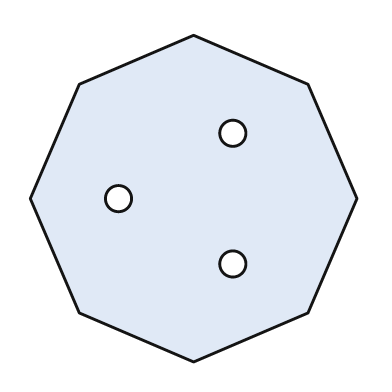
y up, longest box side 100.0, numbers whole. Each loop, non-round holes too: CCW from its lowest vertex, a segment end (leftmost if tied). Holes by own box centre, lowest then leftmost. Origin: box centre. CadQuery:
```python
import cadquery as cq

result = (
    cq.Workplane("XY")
    .moveTo(0.0, -50.0)
    .lineTo(35.0, -35.0)
    .lineTo(50.0, 0.0)
    .lineTo(35.0, 35.0)
    .lineTo(0.0, 50.0)
    .lineTo(-35.0, 35.0)
    .lineTo(-50.0, 0.0)
    .lineTo(-35.0, -35.0)
    .close()
    .moveTo(12.0, -20.0)
    .circle(4.0)
    .moveTo(-23.0, 0.0)
    .circle(4.0)
    .moveTo(12.0, 20.0)
    .circle(4.0)
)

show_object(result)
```